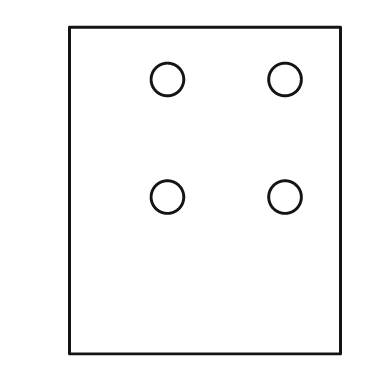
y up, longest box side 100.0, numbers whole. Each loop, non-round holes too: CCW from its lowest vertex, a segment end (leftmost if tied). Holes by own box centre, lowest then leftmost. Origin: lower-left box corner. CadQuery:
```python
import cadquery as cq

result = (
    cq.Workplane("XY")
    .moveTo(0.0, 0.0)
    .lineTo(83.0, 0.0)
    .lineTo(83.0, 100.0)
    .lineTo(0.0, 100.0)
    .close()
    .moveTo(30.0, 48.0)
    .circle(5.0)
    .moveTo(66.0, 48.0)
    .circle(5.0)
    .moveTo(30.0, 84.0)
    .circle(5.0)
    .moveTo(66.0, 84.0)
    .circle(5.0)
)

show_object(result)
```